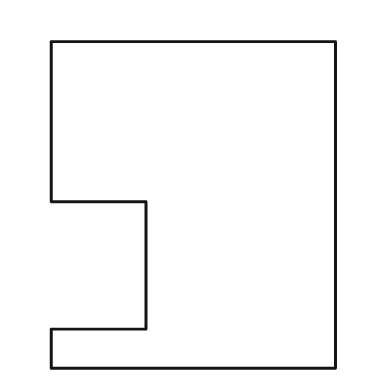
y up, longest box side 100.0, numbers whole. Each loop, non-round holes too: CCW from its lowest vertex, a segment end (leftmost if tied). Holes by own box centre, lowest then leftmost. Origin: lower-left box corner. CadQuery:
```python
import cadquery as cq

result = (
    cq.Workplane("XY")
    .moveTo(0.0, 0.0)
    .lineTo(87.0, 0.0)
    .lineTo(87.0, 100.0)
    .lineTo(0.0, 100.0)
    .lineTo(0.0, 51.0)
    .lineTo(29.0, 51.0)
    .lineTo(29.0, 12.0)
    .lineTo(0.0, 12.0)
    .close()
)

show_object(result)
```